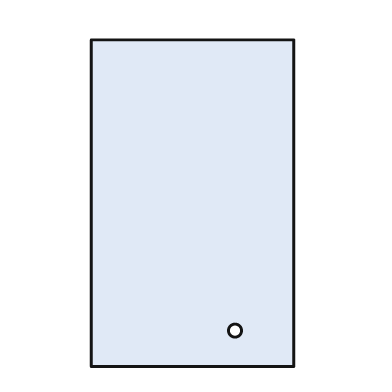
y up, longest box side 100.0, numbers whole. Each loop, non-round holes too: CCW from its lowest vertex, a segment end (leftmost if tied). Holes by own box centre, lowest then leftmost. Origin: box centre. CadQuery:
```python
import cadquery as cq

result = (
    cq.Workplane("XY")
    .moveTo(-31.0, -50.0)
    .lineTo(31.0, -50.0)
    .lineTo(31.0, 50.0)
    .lineTo(-31.0, 50.0)
    .close()
    .moveTo(13.0, -39.0)
    .circle(2.0)
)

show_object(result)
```